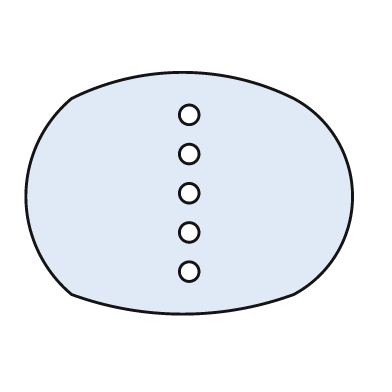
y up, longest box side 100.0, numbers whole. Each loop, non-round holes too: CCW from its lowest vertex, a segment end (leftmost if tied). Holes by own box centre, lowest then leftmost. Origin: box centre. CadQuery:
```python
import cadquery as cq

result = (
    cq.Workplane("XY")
    .moveTo(-36.0, -31.0)
    .threePointArc((-2.0, -37.0), (32.0, -31.0))
    .threePointArc((50.0, -1.0), (32.0, 29.0))
    .threePointArc((-2.0, 37.0), (-36.0, 29.0))
    .threePointArc((-50.0, -1.0), (-36.0, -31.0))
    .close()
    .moveTo(0.0, -24.0)
    .circle(3.0)
    .moveTo(0.0, -12.0)
    .circle(3.0)
    .moveTo(0.0, 0.0)
    .circle(3.0)
    .moveTo(0.0, 12.0)
    .circle(3.0)
    .moveTo(0.0, 24.0)
    .circle(3.0)
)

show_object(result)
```